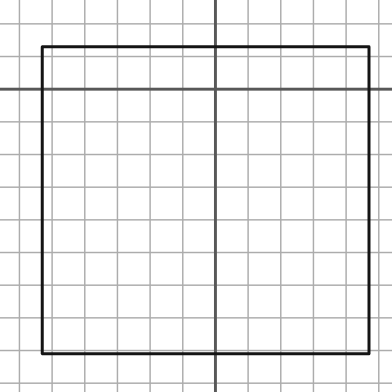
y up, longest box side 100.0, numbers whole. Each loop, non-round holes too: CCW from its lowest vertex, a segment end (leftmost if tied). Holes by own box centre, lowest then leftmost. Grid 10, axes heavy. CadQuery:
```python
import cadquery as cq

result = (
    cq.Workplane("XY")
    .moveTo(-53.0, -81.0)
    .lineTo(47.0, -81.0)
    .lineTo(47.0, 13.0)
    .lineTo(-53.0, 13.0)
    .close()
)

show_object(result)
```